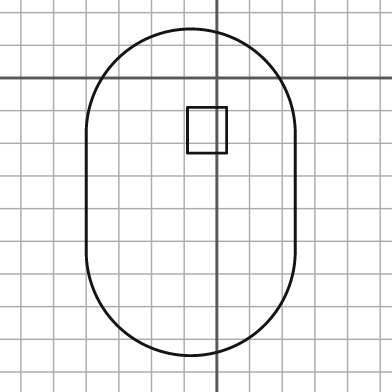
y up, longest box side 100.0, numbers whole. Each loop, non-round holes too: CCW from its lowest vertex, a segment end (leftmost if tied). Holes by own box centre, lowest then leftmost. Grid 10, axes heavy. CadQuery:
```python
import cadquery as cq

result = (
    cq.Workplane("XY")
    .moveTo(-40.0, -53.0)
    .threePointArc((-8.0, -85.0), (24.0, -53.0))
    .lineTo(24.0, -17.0)
    .threePointArc((-8.0, 15.0), (-40.0, -17.0))
    .close()
    .moveTo(-9.0, -23.0)
    .lineTo(3.0, -23.0)
    .lineTo(3.0, -9.0)
    .lineTo(-9.0, -9.0)
    .close()
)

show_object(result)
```